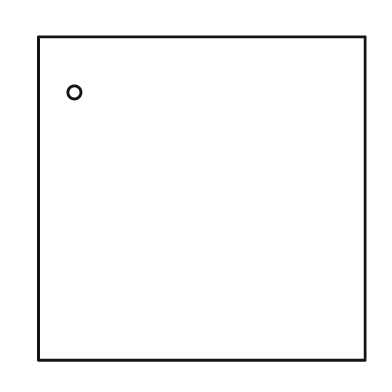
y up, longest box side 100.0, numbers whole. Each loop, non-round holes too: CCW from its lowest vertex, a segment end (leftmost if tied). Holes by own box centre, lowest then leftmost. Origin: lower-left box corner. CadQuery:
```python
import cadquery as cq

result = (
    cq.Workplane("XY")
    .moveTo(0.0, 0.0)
    .lineTo(100.0, 0.0)
    .lineTo(100.0, 99.0)
    .lineTo(0.0, 99.0)
    .close()
    .moveTo(11.0, 82.0)
    .circle(2.0)
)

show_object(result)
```